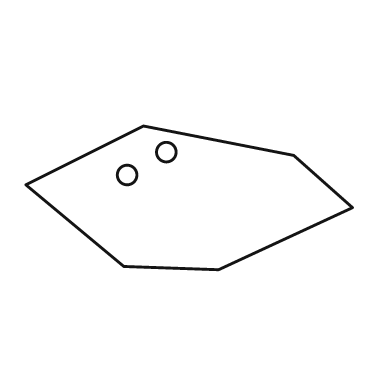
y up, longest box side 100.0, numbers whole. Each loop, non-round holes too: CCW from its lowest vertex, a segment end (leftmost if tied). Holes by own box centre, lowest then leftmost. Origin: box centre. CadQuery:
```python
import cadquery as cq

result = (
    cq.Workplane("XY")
    .moveTo(9.0, -22.0)
    .lineTo(50.0, -3.0)
    .lineTo(32.0, 13.0)
    .lineTo(-14.0, 22.0)
    .lineTo(-50.0, 4.0)
    .lineTo(-20.0, -21.0)
    .close()
    .moveTo(-19.0, 7.0)
    .circle(3.0)
    .moveTo(-7.0, 14.0)
    .circle(3.0)
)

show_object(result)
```